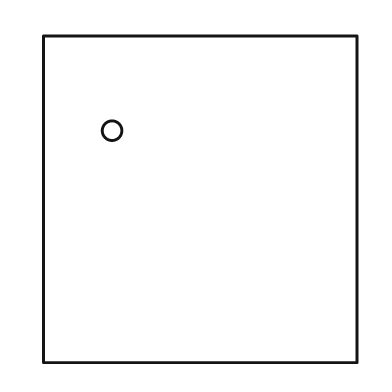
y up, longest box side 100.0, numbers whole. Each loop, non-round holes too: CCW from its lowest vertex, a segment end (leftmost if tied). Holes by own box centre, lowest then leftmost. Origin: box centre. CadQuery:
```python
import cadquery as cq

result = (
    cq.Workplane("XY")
    .moveTo(-48.0, -50.0)
    .lineTo(48.0, -50.0)
    .lineTo(48.0, 50.0)
    .lineTo(-48.0, 50.0)
    .close()
    .moveTo(-27.0, 21.0)
    .circle(3.0)
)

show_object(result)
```